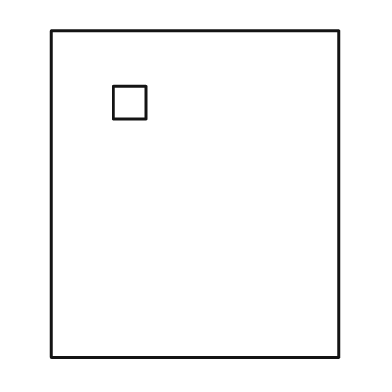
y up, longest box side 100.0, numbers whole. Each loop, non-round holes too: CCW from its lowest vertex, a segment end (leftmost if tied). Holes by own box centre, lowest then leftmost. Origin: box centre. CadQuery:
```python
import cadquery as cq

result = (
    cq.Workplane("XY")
    .moveTo(-44.0, -50.0)
    .lineTo(44.0, -50.0)
    .lineTo(44.0, 50.0)
    .lineTo(-44.0, 50.0)
    .close()
    .moveTo(-25.0, 23.0)
    .lineTo(-15.0, 23.0)
    .lineTo(-15.0, 33.0)
    .lineTo(-25.0, 33.0)
    .close()
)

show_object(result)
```